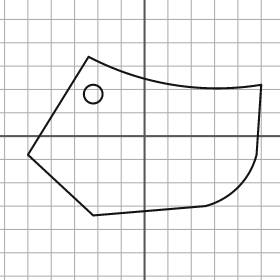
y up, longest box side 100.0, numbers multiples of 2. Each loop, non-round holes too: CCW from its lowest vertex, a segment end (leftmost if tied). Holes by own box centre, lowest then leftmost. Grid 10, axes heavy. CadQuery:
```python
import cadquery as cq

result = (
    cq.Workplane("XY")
    .moveTo(-22.0, -34.0)
    .lineTo(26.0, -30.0)
    .threePointArc((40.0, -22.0), (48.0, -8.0))
    .lineTo(50.0, 22.0)
    .threePointArc((12.0, 22.0), (-24.0, 34.0))
    .lineTo(-50.0, -8.0)
    .close()
    .moveTo(-22.0, 18.0)
    .circle(4.0)
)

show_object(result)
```